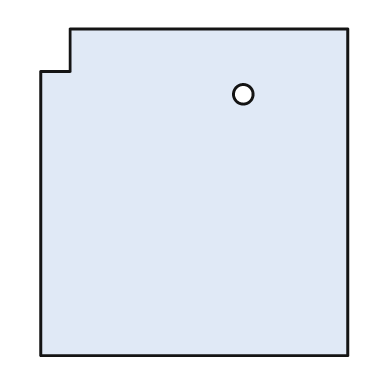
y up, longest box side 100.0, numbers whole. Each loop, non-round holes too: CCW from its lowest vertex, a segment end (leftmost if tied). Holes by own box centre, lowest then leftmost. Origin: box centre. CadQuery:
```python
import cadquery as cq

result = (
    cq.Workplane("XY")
    .moveTo(-47.0, -50.0)
    .lineTo(47.0, -50.0)
    .lineTo(47.0, 50.0)
    .lineTo(-38.0, 50.0)
    .lineTo(-38.0, 37.0)
    .lineTo(-47.0, 37.0)
    .close()
    .moveTo(15.0, 30.0)
    .circle(3.0)
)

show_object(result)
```